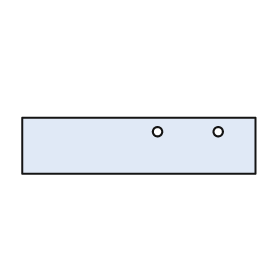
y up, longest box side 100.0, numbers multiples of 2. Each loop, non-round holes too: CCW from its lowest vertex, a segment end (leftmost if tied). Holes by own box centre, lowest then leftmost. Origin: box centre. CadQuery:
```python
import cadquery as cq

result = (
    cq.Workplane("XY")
    .moveTo(-50.0, -12.0)
    .lineTo(50.0, -12.0)
    .lineTo(50.0, 12.0)
    .lineTo(-50.0, 12.0)
    .close()
    .moveTo(8.0, 6.0)
    .circle(2.0)
    .moveTo(34.0, 6.0)
    .circle(2.0)
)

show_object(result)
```